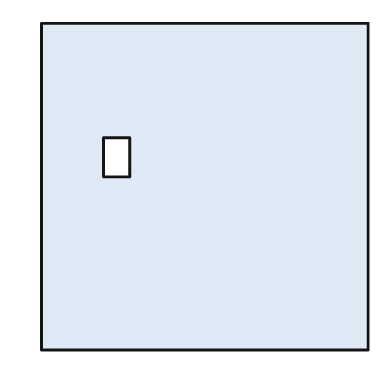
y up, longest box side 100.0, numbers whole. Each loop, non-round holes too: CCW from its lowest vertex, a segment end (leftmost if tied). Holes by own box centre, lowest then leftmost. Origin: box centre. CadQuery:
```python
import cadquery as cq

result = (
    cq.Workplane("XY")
    .moveTo(-50.0, -50.0)
    .lineTo(50.0, -50.0)
    .lineTo(50.0, 50.0)
    .lineTo(-50.0, 50.0)
    .close()
    .moveTo(-31.0, 3.0)
    .lineTo(-23.0, 3.0)
    .lineTo(-23.0, 15.0)
    .lineTo(-31.0, 15.0)
    .close()
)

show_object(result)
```